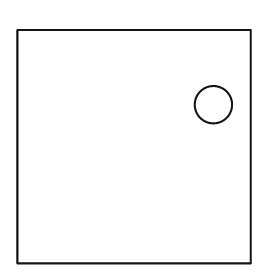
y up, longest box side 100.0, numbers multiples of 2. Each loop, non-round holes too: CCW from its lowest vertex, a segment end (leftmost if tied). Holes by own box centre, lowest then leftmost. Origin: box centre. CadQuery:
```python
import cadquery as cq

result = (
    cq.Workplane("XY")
    .moveTo(-50.0, -50.0)
    .lineTo(50.0, -50.0)
    .lineTo(50.0, 50.0)
    .lineTo(-50.0, 50.0)
    .close()
    .moveTo(34.0, 18.0)
    .circle(8.0)
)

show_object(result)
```